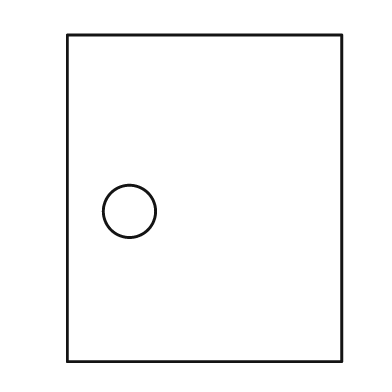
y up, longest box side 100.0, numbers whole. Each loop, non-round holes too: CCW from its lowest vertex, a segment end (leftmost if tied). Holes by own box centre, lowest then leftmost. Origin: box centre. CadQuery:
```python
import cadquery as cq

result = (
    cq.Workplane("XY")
    .moveTo(-42.0, -50.0)
    .lineTo(42.0, -50.0)
    .lineTo(42.0, 50.0)
    .lineTo(-42.0, 50.0)
    .close()
    .moveTo(-23.0, -4.0)
    .circle(8.0)
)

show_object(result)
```